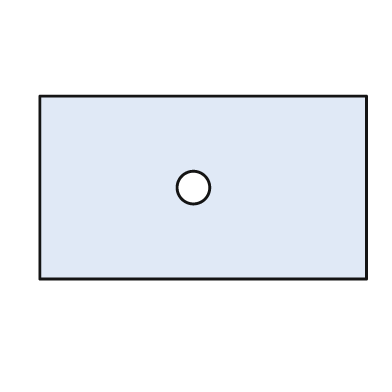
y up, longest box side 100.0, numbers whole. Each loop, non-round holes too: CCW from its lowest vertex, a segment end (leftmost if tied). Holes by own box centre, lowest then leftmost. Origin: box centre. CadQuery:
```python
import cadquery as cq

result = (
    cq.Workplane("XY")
    .moveTo(-50.0, -28.0)
    .lineTo(50.0, -28.0)
    .lineTo(50.0, 28.0)
    .lineTo(-50.0, 28.0)
    .close()
    .moveTo(-3.0, 0.0)
    .circle(5.0)
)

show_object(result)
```